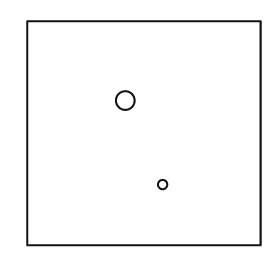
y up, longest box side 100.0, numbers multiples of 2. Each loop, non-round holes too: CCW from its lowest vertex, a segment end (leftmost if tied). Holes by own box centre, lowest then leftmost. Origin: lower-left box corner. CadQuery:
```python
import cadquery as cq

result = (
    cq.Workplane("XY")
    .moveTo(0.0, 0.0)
    .lineTo(100.0, 0.0)
    .lineTo(100.0, 96.0)
    .lineTo(0.0, 96.0)
    .close()
    .moveTo(58.0, 26.0)
    .circle(2.0)
    .moveTo(42.0, 62.0)
    .circle(4.0)
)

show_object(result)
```